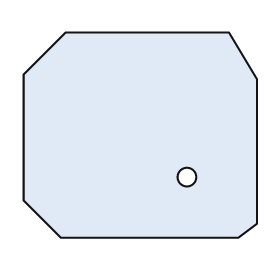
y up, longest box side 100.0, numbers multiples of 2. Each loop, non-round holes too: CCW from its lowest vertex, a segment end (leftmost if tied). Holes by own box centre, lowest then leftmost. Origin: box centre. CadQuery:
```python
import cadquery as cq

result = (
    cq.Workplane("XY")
    .moveTo(-34.0, -44.0)
    .lineTo(42.0, -44.0)
    .lineTo(50.0, -38.0)
    .lineTo(50.0, 24.0)
    .lineTo(38.0, 44.0)
    .lineTo(-32.0, 44.0)
    .lineTo(-50.0, 26.0)
    .lineTo(-50.0, -28.0)
    .close()
    .moveTo(20.0, -18.0)
    .circle(4.0)
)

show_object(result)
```